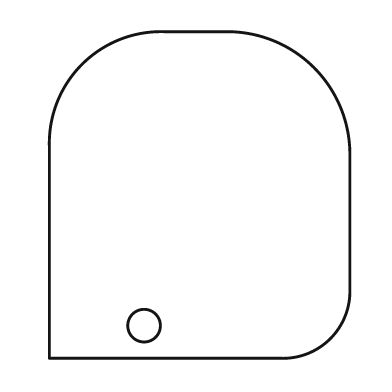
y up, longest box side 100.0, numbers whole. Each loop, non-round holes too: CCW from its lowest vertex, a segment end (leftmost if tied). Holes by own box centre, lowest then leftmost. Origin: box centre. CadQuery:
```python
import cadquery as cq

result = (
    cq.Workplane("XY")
    .moveTo(-46.0, -50.0)
    .lineTo(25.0, -50.0)
    .threePointArc((40.0, -44.0), (46.0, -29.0))
    .lineTo(46.0, 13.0)
    .threePointArc((35.0, 39.0), (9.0, 50.0))
    .lineTo(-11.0, 50.0)
    .threePointArc((-36.0, 40.0), (-46.0, 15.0))
    .close()
    .moveTo(-17.0, -40.0)
    .circle(5.0)
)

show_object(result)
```